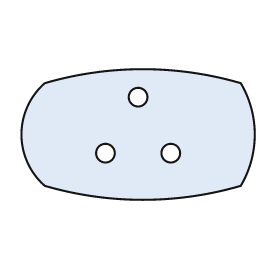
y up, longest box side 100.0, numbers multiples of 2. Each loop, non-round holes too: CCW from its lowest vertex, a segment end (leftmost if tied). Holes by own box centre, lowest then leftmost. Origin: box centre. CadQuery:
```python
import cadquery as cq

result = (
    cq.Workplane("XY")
    .moveTo(-40.0, -22.0)
    .threePointArc((2.0, -28.0), (44.0, -22.0))
    .threePointArc((50.0, 0.0), (44.0, 22.0))
    .threePointArc((2.0, 28.0), (-40.0, 22.0))
    .threePointArc((-50.0, 0.0), (-40.0, -22.0))
    .close()
    .moveTo(-14.0, -8.0)
    .circle(4.0)
    .moveTo(14.0, -8.0)
    .circle(4.0)
    .moveTo(0.0, 16.0)
    .circle(4.0)
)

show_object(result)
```